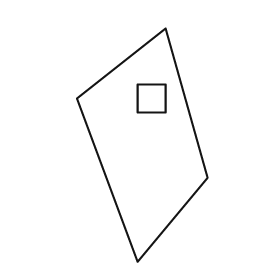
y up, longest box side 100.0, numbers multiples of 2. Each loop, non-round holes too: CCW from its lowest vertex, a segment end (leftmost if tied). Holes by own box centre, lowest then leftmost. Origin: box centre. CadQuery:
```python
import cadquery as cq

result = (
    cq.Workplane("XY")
    .moveTo(-2.0, -50.0)
    .lineTo(28.0, -14.0)
    .lineTo(10.0, 50.0)
    .lineTo(-28.0, 20.0)
    .close()
    .moveTo(-2.0, 14.0)
    .lineTo(10.0, 14.0)
    .lineTo(10.0, 26.0)
    .lineTo(-2.0, 26.0)
    .close()
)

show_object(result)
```